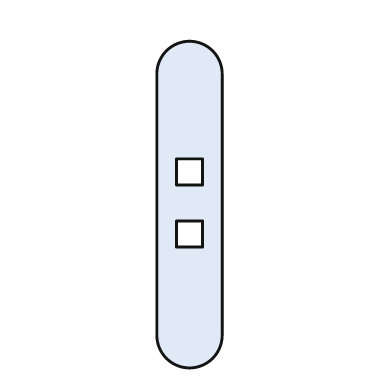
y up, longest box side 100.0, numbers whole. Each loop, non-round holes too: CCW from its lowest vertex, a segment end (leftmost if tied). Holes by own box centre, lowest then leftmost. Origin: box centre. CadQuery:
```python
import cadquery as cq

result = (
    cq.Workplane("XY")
    .moveTo(-10.0, -40.0)
    .threePointArc((0.0, -50.0), (10.0, -40.0))
    .lineTo(10.0, 40.0)
    .threePointArc((0.0, 50.0), (-10.0, 40.0))
    .close()
    .moveTo(-4.0, -13.0)
    .lineTo(4.0, -13.0)
    .lineTo(4.0, -5.0)
    .lineTo(-4.0, -5.0)
    .close()
    .moveTo(-4.0, 6.0)
    .lineTo(4.0, 6.0)
    .lineTo(4.0, 14.0)
    .lineTo(-4.0, 14.0)
    .close()
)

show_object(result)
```